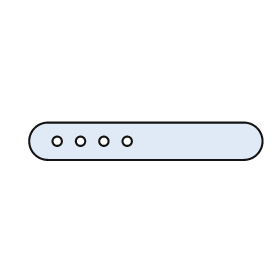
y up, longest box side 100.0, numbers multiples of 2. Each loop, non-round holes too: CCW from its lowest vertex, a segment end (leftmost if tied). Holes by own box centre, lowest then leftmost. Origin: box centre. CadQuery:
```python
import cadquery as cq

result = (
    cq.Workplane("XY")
    .moveTo(-42.0, -8.0)
    .lineTo(42.0, -8.0)
    .threePointArc((50.0, 0.0), (42.0, 8.0))
    .lineTo(-42.0, 8.0)
    .threePointArc((-50.0, 0.0), (-42.0, -8.0))
    .close()
    .moveTo(-38.0, 0.0)
    .circle(2.0)
    .moveTo(-28.0, 0.0)
    .circle(2.0)
    .moveTo(-18.0, 0.0)
    .circle(2.0)
    .moveTo(-8.0, 0.0)
    .circle(2.0)
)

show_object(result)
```